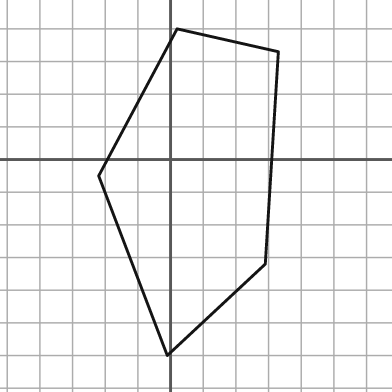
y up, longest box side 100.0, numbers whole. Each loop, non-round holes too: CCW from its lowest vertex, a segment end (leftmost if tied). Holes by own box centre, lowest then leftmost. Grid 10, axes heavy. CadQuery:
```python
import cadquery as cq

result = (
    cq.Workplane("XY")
    .moveTo(-1.0, -60.0)
    .lineTo(29.0, -32.0)
    .lineTo(33.0, 33.0)
    .lineTo(2.0, 40.0)
    .lineTo(-22.0, -5.0)
    .close()
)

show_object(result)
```